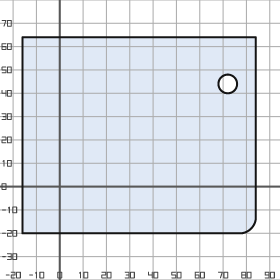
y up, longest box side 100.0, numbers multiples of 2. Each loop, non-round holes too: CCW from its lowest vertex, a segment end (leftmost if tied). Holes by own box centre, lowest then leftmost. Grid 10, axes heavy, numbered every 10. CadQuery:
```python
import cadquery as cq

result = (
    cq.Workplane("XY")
    .moveTo(-16.0, -20.0)
    .lineTo(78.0, -20.0)
    .threePointArc((82.0, -18.0), (84.0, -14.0))
    .lineTo(84.0, 64.0)
    .lineTo(-16.0, 64.0)
    .close()
    .moveTo(72.0, 44.0)
    .circle(4.0)
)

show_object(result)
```